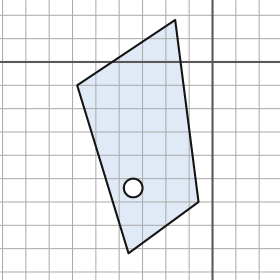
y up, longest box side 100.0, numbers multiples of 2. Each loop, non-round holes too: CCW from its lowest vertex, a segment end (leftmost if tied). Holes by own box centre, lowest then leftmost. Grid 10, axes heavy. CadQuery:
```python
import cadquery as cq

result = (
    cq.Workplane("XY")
    .moveTo(-36.0, -82.0)
    .lineTo(-6.0, -60.0)
    .lineTo(-16.0, 18.0)
    .lineTo(-58.0, -10.0)
    .close()
    .moveTo(-34.0, -54.0)
    .circle(4.0)
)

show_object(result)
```